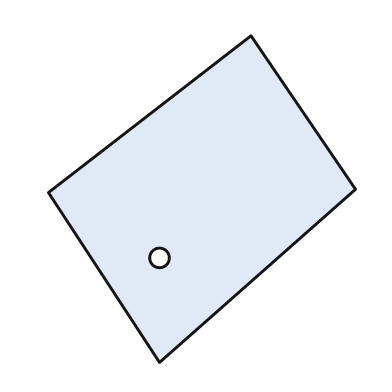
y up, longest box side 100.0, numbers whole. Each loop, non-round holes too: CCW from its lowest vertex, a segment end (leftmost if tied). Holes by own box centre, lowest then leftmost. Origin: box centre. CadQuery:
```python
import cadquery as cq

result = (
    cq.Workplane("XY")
    .moveTo(-13.0, -50.0)
    .lineTo(47.0, 3.0)
    .lineTo(15.0, 50.0)
    .lineTo(-47.0, 2.0)
    .close()
    .moveTo(-13.0, -18.0)
    .circle(3.0)
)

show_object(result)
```